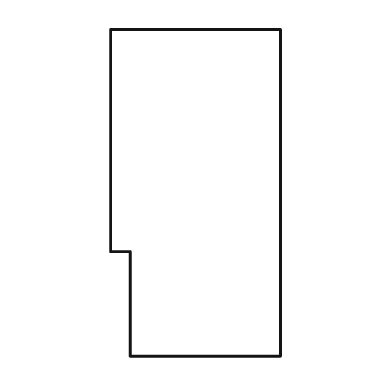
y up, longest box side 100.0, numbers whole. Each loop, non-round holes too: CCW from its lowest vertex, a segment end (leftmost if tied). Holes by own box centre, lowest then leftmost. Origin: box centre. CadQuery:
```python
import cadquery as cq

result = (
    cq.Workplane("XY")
    .moveTo(-20.0, -50.0)
    .lineTo(26.0, -50.0)
    .lineTo(26.0, 50.0)
    .lineTo(-26.0, 50.0)
    .lineTo(-26.0, -18.0)
    .lineTo(-20.0, -18.0)
    .close()
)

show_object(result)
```